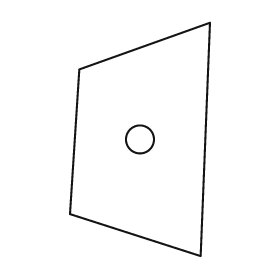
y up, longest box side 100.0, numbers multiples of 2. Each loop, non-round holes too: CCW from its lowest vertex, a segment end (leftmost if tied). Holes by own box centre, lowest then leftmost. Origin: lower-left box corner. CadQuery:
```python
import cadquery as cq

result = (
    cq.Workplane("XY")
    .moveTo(56.0, 0.0)
    .lineTo(60.0, 100.0)
    .lineTo(4.0, 80.0)
    .lineTo(0.0, 18.0)
    .close()
    .moveTo(30.0, 50.0)
    .circle(6.0)
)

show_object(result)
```